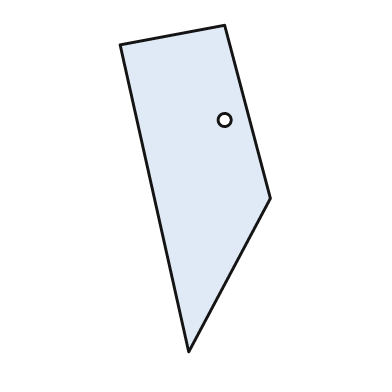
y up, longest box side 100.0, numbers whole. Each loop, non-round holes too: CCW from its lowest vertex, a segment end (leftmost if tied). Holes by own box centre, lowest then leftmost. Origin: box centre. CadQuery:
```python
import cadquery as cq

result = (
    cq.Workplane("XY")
    .moveTo(-2.0, -50.0)
    .lineTo(23.0, -3.0)
    .lineTo(9.0, 50.0)
    .lineTo(-23.0, 44.0)
    .close()
    .moveTo(9.0, 21.0)
    .circle(2.0)
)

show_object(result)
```